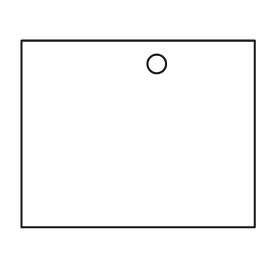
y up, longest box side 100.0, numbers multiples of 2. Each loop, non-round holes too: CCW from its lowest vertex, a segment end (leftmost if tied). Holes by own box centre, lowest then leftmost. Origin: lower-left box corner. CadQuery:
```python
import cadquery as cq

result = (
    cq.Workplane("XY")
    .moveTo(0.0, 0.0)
    .lineTo(100.0, 0.0)
    .lineTo(100.0, 80.0)
    .lineTo(0.0, 80.0)
    .close()
    .moveTo(58.0, 70.0)
    .circle(4.0)
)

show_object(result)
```